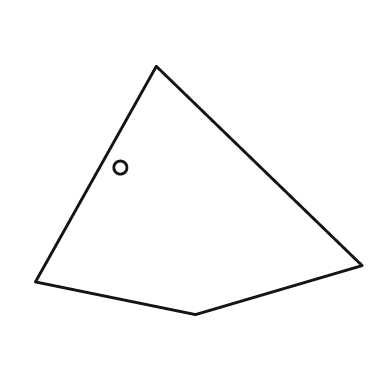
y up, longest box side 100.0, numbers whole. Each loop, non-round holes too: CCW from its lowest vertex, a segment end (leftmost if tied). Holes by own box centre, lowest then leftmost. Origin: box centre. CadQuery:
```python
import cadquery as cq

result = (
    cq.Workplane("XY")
    .moveTo(-1.0, -38.0)
    .lineTo(50.0, -23.0)
    .lineTo(-13.0, 38.0)
    .lineTo(-50.0, -28.0)
    .close()
    .moveTo(-24.0, 7.0)
    .circle(2.0)
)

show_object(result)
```